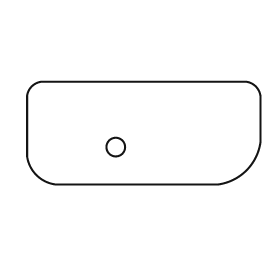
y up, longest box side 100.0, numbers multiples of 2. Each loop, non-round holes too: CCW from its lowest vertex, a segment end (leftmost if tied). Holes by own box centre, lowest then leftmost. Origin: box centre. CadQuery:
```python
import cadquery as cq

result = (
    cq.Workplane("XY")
    .moveTo(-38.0, -22.0)
    .lineTo(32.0, -22.0)
    .threePointArc((44.0, -16.0), (50.0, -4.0))
    .lineTo(50.0, 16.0)
    .threePointArc((48.0, 20.0), (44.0, 22.0))
    .lineTo(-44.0, 22.0)
    .threePointArc((-48.0, 20.0), (-50.0, 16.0))
    .lineTo(-50.0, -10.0)
    .threePointArc((-46.0, -18.0), (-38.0, -22.0))
    .close()
    .moveTo(-12.0, -6.0)
    .circle(4.0)
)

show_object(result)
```